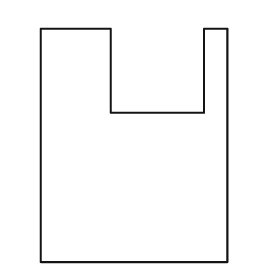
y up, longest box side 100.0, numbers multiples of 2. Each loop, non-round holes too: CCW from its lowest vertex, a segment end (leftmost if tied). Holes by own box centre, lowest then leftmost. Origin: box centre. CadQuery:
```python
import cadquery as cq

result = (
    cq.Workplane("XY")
    .moveTo(-40.0, -50.0)
    .lineTo(40.0, -50.0)
    .lineTo(40.0, 50.0)
    .lineTo(30.0, 50.0)
    .lineTo(30.0, 14.0)
    .lineTo(-10.0, 14.0)
    .lineTo(-10.0, 50.0)
    .lineTo(-40.0, 50.0)
    .close()
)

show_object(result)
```